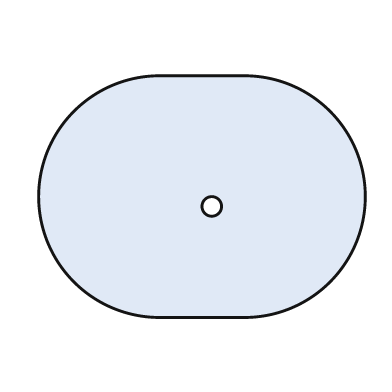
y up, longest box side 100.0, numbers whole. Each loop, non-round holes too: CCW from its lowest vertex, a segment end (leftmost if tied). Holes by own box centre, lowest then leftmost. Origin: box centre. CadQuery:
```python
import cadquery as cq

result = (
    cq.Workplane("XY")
    .moveTo(-13.0, -37.0)
    .lineTo(13.0, -37.0)
    .threePointArc((50.0, 0.0), (13.0, 37.0))
    .lineTo(-13.0, 37.0)
    .threePointArc((-50.0, 0.0), (-13.0, -37.0))
    .close()
    .moveTo(3.0, -3.0)
    .circle(3.0)
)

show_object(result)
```